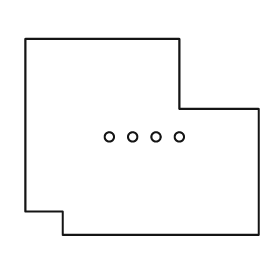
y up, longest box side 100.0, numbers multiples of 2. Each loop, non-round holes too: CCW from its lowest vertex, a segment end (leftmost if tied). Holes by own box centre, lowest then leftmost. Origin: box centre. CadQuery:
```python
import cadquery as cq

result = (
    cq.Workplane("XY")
    .moveTo(-34.0, -42.0)
    .lineTo(50.0, -42.0)
    .lineTo(50.0, 12.0)
    .lineTo(16.0, 12.0)
    .lineTo(16.0, 42.0)
    .lineTo(-50.0, 42.0)
    .lineTo(-50.0, -32.0)
    .lineTo(-34.0, -32.0)
    .close()
    .moveTo(-14.0, 0.0)
    .circle(2.0)
    .moveTo(-4.0, 0.0)
    .circle(2.0)
    .moveTo(6.0, 0.0)
    .circle(2.0)
    .moveTo(16.0, 0.0)
    .circle(2.0)
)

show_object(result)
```